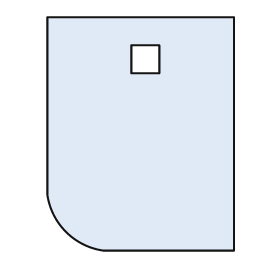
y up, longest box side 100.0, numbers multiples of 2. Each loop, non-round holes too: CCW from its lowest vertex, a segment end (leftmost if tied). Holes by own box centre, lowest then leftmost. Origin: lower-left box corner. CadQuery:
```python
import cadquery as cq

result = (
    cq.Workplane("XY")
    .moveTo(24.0, 0.0)
    .lineTo(80.0, 0.0)
    .lineTo(80.0, 100.0)
    .lineTo(0.0, 100.0)
    .lineTo(0.0, 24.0)
    .threePointArc((8.0, 8.0), (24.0, 0.0))
    .close()
    .moveTo(36.0, 76.0)
    .lineTo(48.0, 76.0)
    .lineTo(48.0, 88.0)
    .lineTo(36.0, 88.0)
    .close()
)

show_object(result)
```